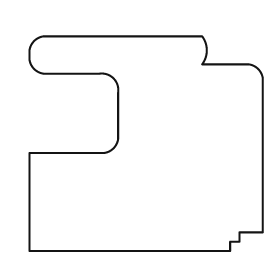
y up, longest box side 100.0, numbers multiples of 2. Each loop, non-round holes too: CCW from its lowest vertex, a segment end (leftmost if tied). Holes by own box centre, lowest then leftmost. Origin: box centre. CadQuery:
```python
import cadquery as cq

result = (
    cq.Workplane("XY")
    .moveTo(-50.0, -46.0)
    .lineTo(36.0, -46.0)
    .lineTo(36.0, -42.0)
    .lineTo(40.0, -42.0)
    .lineTo(40.0, -38.0)
    .lineTo(50.0, -38.0)
    .lineTo(50.0, 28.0)
    .threePointArc((48.0, 32.0), (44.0, 34.0))
    .lineTo(24.0, 34.0)
    .threePointArc((26.0, 40.0), (24.0, 46.0))
    .lineTo(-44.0, 46.0)
    .threePointArc((-48.0, 44.0), (-50.0, 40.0))
    .lineTo(-50.0, 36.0)
    .threePointArc((-48.0, 32.0), (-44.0, 30.0))
    .lineTo(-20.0, 30.0)
    .threePointArc((-14.0, 28.0), (-12.0, 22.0))
    .lineTo(-12.0, 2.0)
    .threePointArc((-14.0, -2.0), (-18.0, -4.0))
    .lineTo(-50.0, -4.0)
    .close()
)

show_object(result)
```